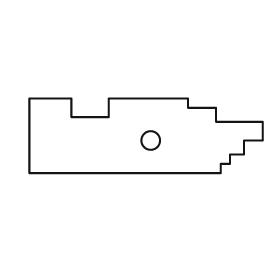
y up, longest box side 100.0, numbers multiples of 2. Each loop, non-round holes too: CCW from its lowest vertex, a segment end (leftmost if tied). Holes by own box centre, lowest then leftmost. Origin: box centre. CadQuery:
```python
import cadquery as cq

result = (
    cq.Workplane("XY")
    .moveTo(-50.0, -16.0)
    .lineTo(32.0, -16.0)
    .lineTo(32.0, -12.0)
    .lineTo(36.0, -12.0)
    .lineTo(36.0, -8.0)
    .lineTo(42.0, -8.0)
    .lineTo(42.0, -2.0)
    .lineTo(50.0, -2.0)
    .lineTo(50.0, 6.0)
    .lineTo(30.0, 6.0)
    .lineTo(30.0, 12.0)
    .lineTo(18.0, 12.0)
    .lineTo(18.0, 16.0)
    .lineTo(-16.0, 16.0)
    .lineTo(-16.0, 8.0)
    .lineTo(-32.0, 8.0)
    .lineTo(-32.0, 16.0)
    .lineTo(-50.0, 16.0)
    .close()
    .moveTo(2.0, -2.0)
    .circle(4.0)
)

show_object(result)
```